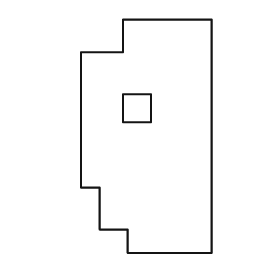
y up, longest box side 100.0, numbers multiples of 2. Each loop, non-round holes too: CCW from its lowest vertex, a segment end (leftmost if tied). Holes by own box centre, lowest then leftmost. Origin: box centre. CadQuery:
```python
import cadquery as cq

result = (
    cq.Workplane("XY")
    .moveTo(-8.0, -50.0)
    .lineTo(28.0, -50.0)
    .lineTo(28.0, 50.0)
    .lineTo(-10.0, 50.0)
    .lineTo(-10.0, 36.0)
    .lineTo(-28.0, 36.0)
    .lineTo(-28.0, -22.0)
    .lineTo(-20.0, -22.0)
    .lineTo(-20.0, -40.0)
    .lineTo(-8.0, -40.0)
    .close()
    .moveTo(-10.0, 6.0)
    .lineTo(2.0, 6.0)
    .lineTo(2.0, 18.0)
    .lineTo(-10.0, 18.0)
    .close()
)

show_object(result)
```